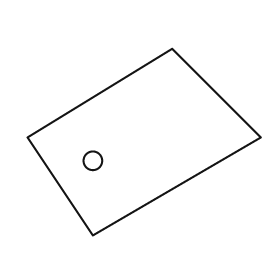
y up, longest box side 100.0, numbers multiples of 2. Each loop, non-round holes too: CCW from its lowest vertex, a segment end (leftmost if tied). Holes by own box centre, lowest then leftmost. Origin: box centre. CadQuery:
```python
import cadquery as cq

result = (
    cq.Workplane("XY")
    .moveTo(-22.0, -40.0)
    .lineTo(50.0, 2.0)
    .lineTo(12.0, 40.0)
    .lineTo(-50.0, 2.0)
    .close()
    .moveTo(-22.0, -8.0)
    .circle(4.0)
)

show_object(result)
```